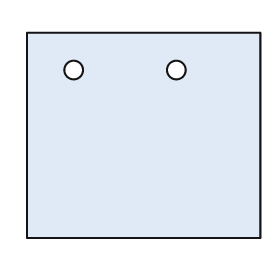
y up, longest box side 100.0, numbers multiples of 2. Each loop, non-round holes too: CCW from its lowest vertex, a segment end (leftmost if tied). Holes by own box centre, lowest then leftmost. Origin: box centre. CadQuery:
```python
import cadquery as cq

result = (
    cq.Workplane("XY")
    .moveTo(-50.0, -44.0)
    .lineTo(50.0, -44.0)
    .lineTo(50.0, 44.0)
    .lineTo(-50.0, 44.0)
    .close()
    .moveTo(-30.0, 28.0)
    .circle(4.0)
    .moveTo(14.0, 28.0)
    .circle(4.0)
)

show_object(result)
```